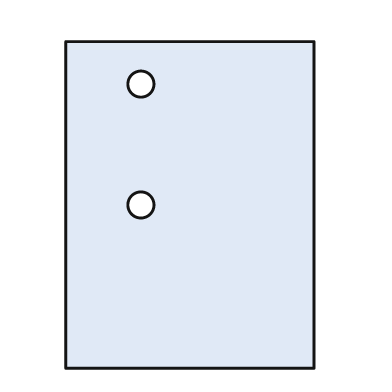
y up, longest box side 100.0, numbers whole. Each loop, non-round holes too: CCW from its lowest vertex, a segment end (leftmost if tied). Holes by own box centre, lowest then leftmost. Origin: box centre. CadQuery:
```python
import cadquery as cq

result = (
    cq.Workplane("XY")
    .moveTo(-38.0, -50.0)
    .lineTo(38.0, -50.0)
    .lineTo(38.0, 50.0)
    .lineTo(-38.0, 50.0)
    .close()
    .moveTo(-15.0, 0.0)
    .circle(4.0)
    .moveTo(-15.0, 37.0)
    .circle(4.0)
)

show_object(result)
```